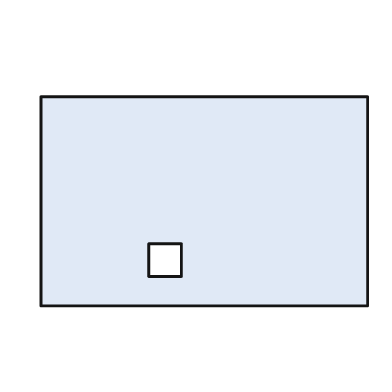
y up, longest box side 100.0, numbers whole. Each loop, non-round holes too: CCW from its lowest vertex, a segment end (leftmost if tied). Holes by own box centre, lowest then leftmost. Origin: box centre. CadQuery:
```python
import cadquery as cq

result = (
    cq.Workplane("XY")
    .moveTo(-50.0, -32.0)
    .lineTo(50.0, -32.0)
    .lineTo(50.0, 32.0)
    .lineTo(-50.0, 32.0)
    .close()
    .moveTo(-17.0, -23.0)
    .lineTo(-7.0, -23.0)
    .lineTo(-7.0, -13.0)
    .lineTo(-17.0, -13.0)
    .close()
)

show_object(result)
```